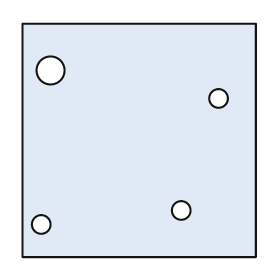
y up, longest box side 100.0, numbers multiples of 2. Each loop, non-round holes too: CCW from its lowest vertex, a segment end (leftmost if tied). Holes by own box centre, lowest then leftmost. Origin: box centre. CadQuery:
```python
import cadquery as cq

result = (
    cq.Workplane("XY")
    .moveTo(-50.0, -50.0)
    .lineTo(50.0, -50.0)
    .lineTo(50.0, 50.0)
    .lineTo(-50.0, 50.0)
    .close()
    .moveTo(-42.0, -36.0)
    .circle(4.0)
    .moveTo(18.0, -30.0)
    .circle(4.0)
    .moveTo(34.0, 18.0)
    .circle(4.0)
    .moveTo(-38.0, 30.0)
    .circle(6.0)
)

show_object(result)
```